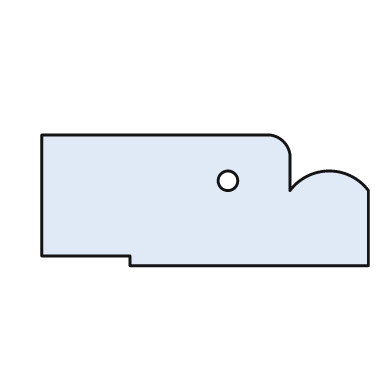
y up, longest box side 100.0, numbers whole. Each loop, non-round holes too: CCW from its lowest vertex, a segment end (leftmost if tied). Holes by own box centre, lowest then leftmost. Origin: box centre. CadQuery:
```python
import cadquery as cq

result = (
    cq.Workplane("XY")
    .moveTo(-23.0, -20.0)
    .lineTo(50.0, -20.0)
    .lineTo(50.0, 3.0)
    .threePointArc((38.0, 9.0), (26.0, 3.0))
    .lineTo(26.0, 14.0)
    .threePointArc((24.0, 18.0), (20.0, 20.0))
    .lineTo(-50.0, 20.0)
    .lineTo(-50.0, -17.0)
    .lineTo(-23.0, -17.0)
    .close()
    .moveTo(7.0, 6.0)
    .circle(3.0)
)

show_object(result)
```